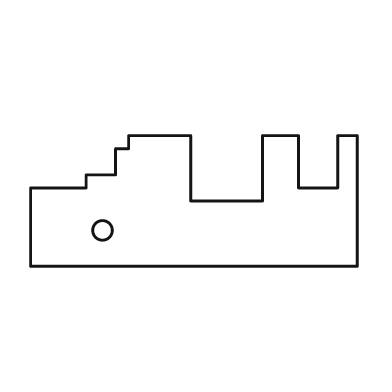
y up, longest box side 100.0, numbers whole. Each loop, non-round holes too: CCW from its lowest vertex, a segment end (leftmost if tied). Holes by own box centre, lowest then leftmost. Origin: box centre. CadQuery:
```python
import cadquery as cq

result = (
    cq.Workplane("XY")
    .moveTo(-50.0, -20.0)
    .lineTo(50.0, -20.0)
    .lineTo(50.0, 20.0)
    .lineTo(44.0, 20.0)
    .lineTo(44.0, 4.0)
    .lineTo(32.0, 4.0)
    .lineTo(32.0, 20.0)
    .lineTo(21.0, 20.0)
    .lineTo(21.0, 0.0)
    .lineTo(-1.0, 0.0)
    .lineTo(-1.0, 20.0)
    .lineTo(-20.0, 20.0)
    .lineTo(-20.0, 16.0)
    .lineTo(-24.0, 16.0)
    .lineTo(-24.0, 8.0)
    .lineTo(-33.0, 8.0)
    .lineTo(-33.0, 4.0)
    .lineTo(-50.0, 4.0)
    .close()
    .moveTo(-28.0, -9.0)
    .circle(3.0)
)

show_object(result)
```